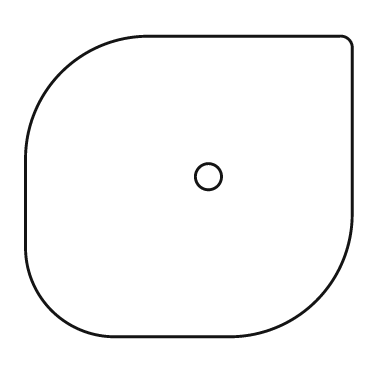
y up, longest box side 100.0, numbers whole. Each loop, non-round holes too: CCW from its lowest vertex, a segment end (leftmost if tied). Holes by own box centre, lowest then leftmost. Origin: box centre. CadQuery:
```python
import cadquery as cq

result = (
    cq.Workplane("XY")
    .moveTo(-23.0, -46.0)
    .lineTo(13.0, -46.0)
    .threePointArc((39.0, -35.0), (50.0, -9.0))
    .lineTo(50.0, 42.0)
    .threePointArc((49.0, 45.0), (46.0, 46.0))
    .lineTo(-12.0, 46.0)
    .threePointArc((-39.0, 35.0), (-50.0, 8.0))
    .lineTo(-50.0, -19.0)
    .threePointArc((-42.0, -38.0), (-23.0, -46.0))
    .close()
    .moveTo(6.0, 3.0)
    .circle(4.0)
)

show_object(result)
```